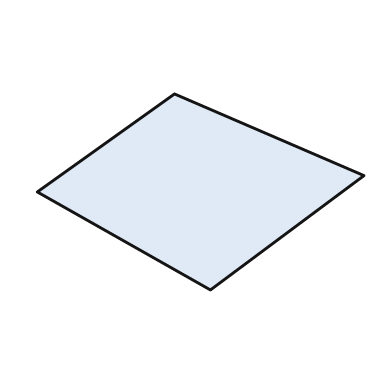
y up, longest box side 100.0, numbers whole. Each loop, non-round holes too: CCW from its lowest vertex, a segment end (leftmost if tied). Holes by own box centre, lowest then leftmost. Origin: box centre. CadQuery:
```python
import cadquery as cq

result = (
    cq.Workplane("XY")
    .moveTo(3.0, -30.0)
    .lineTo(50.0, 5.0)
    .lineTo(-8.0, 30.0)
    .lineTo(-50.0, 0.0)
    .close()
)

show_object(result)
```